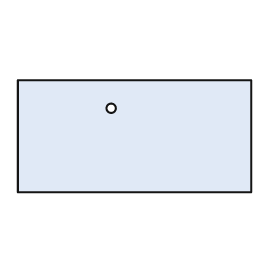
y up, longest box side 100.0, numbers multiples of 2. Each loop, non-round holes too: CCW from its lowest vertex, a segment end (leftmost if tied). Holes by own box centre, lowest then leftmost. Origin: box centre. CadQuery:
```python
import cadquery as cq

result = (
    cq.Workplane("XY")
    .moveTo(-50.0, -24.0)
    .lineTo(50.0, -24.0)
    .lineTo(50.0, 24.0)
    .lineTo(-50.0, 24.0)
    .close()
    .moveTo(-10.0, 12.0)
    .circle(2.0)
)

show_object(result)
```